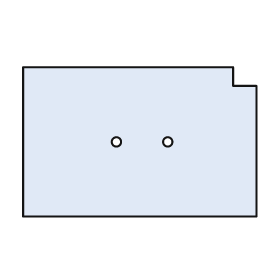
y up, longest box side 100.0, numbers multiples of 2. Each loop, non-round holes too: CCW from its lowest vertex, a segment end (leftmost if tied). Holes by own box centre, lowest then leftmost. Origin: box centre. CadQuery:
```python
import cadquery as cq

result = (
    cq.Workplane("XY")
    .moveTo(-50.0, -32.0)
    .lineTo(50.0, -32.0)
    .lineTo(50.0, 24.0)
    .lineTo(40.0, 24.0)
    .lineTo(40.0, 32.0)
    .lineTo(-50.0, 32.0)
    .close()
    .moveTo(-10.0, 0.0)
    .circle(2.0)
    .moveTo(12.0, 0.0)
    .circle(2.0)
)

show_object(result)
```